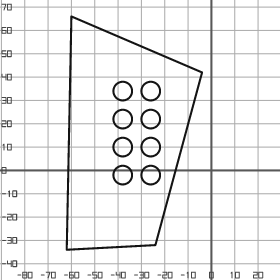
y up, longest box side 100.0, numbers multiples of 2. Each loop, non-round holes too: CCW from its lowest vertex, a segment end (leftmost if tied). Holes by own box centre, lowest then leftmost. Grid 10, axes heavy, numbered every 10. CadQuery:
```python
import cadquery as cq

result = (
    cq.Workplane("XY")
    .moveTo(-62.0, -34.0)
    .lineTo(-24.0, -32.0)
    .lineTo(-4.0, 42.0)
    .lineTo(-60.0, 66.0)
    .close()
    .moveTo(-38.0, -2.0)
    .circle(4.0)
    .moveTo(-26.0, -2.0)
    .circle(4.0)
    .moveTo(-38.0, 10.0)
    .circle(4.0)
    .moveTo(-26.0, 10.0)
    .circle(4.0)
    .moveTo(-38.0, 22.0)
    .circle(4.0)
    .moveTo(-26.0, 22.0)
    .circle(4.0)
    .moveTo(-38.0, 34.0)
    .circle(4.0)
    .moveTo(-26.0, 34.0)
    .circle(4.0)
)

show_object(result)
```